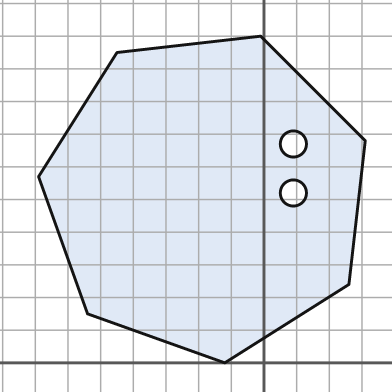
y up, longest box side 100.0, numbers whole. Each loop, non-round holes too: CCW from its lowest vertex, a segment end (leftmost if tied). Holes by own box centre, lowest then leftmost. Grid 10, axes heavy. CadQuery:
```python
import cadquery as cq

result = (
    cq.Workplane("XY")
    .moveTo(-12.0, 0.0)
    .lineTo(26.0, 24.0)
    .lineTo(31.0, 68.0)
    .lineTo(-1.0, 100.0)
    .lineTo(-45.0, 95.0)
    .lineTo(-69.0, 57.0)
    .lineTo(-54.0, 15.0)
    .close()
    .moveTo(9.0, 52.0)
    .circle(4.0)
    .moveTo(9.0, 67.0)
    .circle(4.0)
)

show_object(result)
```